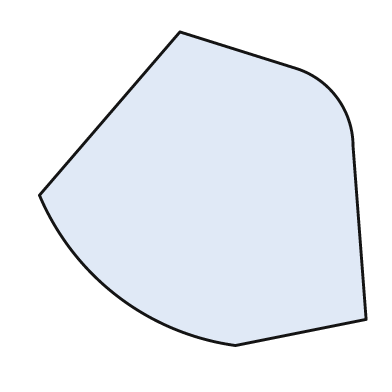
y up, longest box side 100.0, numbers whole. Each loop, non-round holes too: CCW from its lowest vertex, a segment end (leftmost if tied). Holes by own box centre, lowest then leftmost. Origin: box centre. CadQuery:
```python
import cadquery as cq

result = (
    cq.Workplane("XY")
    .moveTo(10.0, -48.0)
    .lineTo(50.0, -40.0)
    .lineTo(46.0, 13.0)
    .threePointArc((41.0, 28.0), (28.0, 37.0))
    .lineTo(-7.0, 48.0)
    .lineTo(-50.0, -2.0)
    .threePointArc((-26.0, -33.0), (10.0, -48.0))
    .close()
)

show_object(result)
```